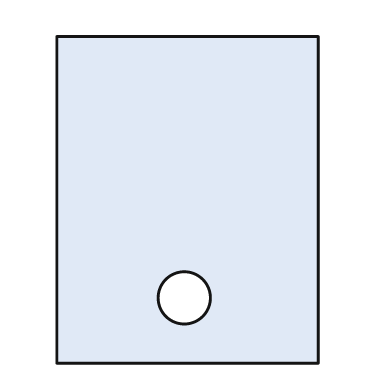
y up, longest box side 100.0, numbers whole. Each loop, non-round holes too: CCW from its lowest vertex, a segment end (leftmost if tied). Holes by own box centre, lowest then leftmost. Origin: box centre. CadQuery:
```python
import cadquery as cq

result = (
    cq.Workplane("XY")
    .moveTo(-40.0, -50.0)
    .lineTo(40.0, -50.0)
    .lineTo(40.0, 50.0)
    .lineTo(-40.0, 50.0)
    .close()
    .moveTo(-1.0, -30.0)
    .circle(8.0)
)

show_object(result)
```